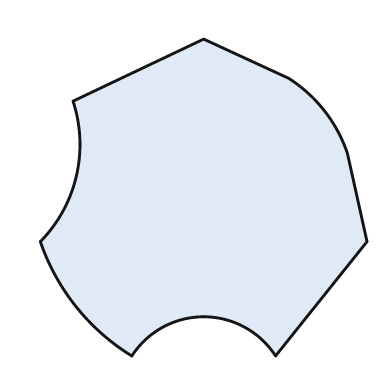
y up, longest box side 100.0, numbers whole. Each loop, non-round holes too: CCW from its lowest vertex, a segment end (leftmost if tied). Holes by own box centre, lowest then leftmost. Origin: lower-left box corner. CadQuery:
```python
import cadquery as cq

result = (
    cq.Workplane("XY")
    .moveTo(28.0, 0.0)
    .threePointArc((50.0, 12.0), (72.0, 0.0))
    .lineTo(100.0, 35.0)
    .lineTo(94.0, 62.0)
    .threePointArc((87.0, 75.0), (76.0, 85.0))
    .lineTo(50.0, 97.0)
    .lineTo(10.0, 78.0)
    .threePointArc((11.0, 55.0), (0.0, 35.0))
    .threePointArc((11.0, 15.0), (28.0, 0.0))
    .close()
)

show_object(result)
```